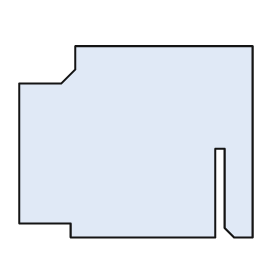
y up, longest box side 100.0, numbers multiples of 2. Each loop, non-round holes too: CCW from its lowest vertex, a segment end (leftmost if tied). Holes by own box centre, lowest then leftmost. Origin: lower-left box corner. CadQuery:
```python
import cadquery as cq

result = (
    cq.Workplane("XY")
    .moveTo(22.0, 0.0)
    .lineTo(84.0, 0.0)
    .lineTo(84.0, 38.0)
    .lineTo(88.0, 38.0)
    .lineTo(88.0, 4.0)
    .lineTo(92.0, 0.0)
    .lineTo(100.0, 0.0)
    .lineTo(100.0, 82.0)
    .lineTo(24.0, 82.0)
    .lineTo(24.0, 72.0)
    .lineTo(18.0, 66.0)
    .lineTo(0.0, 66.0)
    .lineTo(0.0, 6.0)
    .lineTo(22.0, 6.0)
    .close()
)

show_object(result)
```